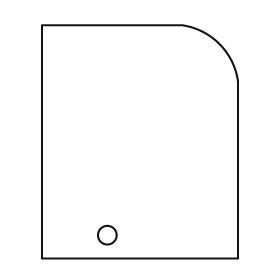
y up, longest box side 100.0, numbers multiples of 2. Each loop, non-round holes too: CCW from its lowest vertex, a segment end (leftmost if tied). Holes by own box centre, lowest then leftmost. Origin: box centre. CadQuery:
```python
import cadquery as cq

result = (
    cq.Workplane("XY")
    .moveTo(-42.0, -50.0)
    .lineTo(42.0, -50.0)
    .lineTo(42.0, 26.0)
    .threePointArc((34.0, 42.0), (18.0, 50.0))
    .lineTo(-42.0, 50.0)
    .close()
    .moveTo(-14.0, -40.0)
    .circle(4.0)
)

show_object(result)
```